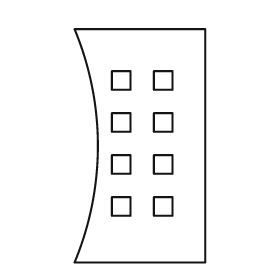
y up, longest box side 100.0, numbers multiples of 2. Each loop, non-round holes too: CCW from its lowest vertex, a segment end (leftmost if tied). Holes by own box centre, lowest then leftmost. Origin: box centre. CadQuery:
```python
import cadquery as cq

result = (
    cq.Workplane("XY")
    .moveTo(-28.0, -50.0)
    .lineTo(28.0, -50.0)
    .lineTo(28.0, 50.0)
    .lineTo(-28.0, 50.0)
    .threePointArc((-18.0, 0.0), (-28.0, -50.0))
    .close()
    .moveTo(-12.0, -30.0)
    .lineTo(-4.0, -30.0)
    .lineTo(-4.0, -22.0)
    .lineTo(-12.0, -22.0)
    .close()
    .moveTo(6.0, -30.0)
    .lineTo(14.0, -30.0)
    .lineTo(14.0, -22.0)
    .lineTo(6.0, -22.0)
    .close()
    .moveTo(-12.0, -12.0)
    .lineTo(-4.0, -12.0)
    .lineTo(-4.0, -4.0)
    .lineTo(-12.0, -4.0)
    .close()
    .moveTo(6.0, -12.0)
    .lineTo(14.0, -12.0)
    .lineTo(14.0, -4.0)
    .lineTo(6.0, -4.0)
    .close()
    .moveTo(-12.0, 6.0)
    .lineTo(-4.0, 6.0)
    .lineTo(-4.0, 14.0)
    .lineTo(-12.0, 14.0)
    .close()
    .moveTo(6.0, 6.0)
    .lineTo(14.0, 6.0)
    .lineTo(14.0, 14.0)
    .lineTo(6.0, 14.0)
    .close()
    .moveTo(-12.0, 24.0)
    .lineTo(-4.0, 24.0)
    .lineTo(-4.0, 32.0)
    .lineTo(-12.0, 32.0)
    .close()
    .moveTo(6.0, 24.0)
    .lineTo(14.0, 24.0)
    .lineTo(14.0, 32.0)
    .lineTo(6.0, 32.0)
    .close()
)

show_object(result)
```